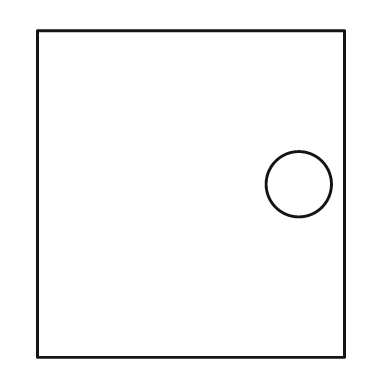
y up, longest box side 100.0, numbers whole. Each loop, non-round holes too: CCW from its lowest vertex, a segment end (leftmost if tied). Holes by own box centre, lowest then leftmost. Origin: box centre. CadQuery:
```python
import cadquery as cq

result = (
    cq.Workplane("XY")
    .moveTo(-47.0, -50.0)
    .lineTo(47.0, -50.0)
    .lineTo(47.0, 50.0)
    .lineTo(-47.0, 50.0)
    .close()
    .moveTo(33.0, 3.0)
    .circle(10.0)
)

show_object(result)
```